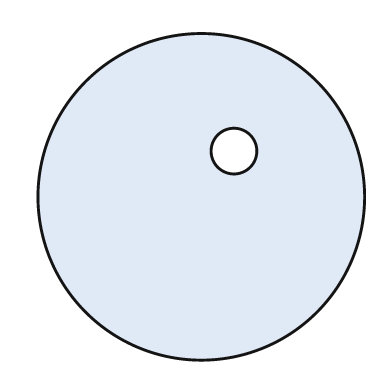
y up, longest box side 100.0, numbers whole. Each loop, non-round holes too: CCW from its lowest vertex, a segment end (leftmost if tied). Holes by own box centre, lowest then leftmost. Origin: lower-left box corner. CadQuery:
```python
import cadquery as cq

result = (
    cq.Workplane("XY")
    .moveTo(50.0, 50.0)
    .circle(50.0)
    .moveTo(60.0, 64.0)
    .circle(7.0)
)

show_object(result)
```